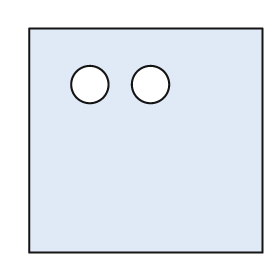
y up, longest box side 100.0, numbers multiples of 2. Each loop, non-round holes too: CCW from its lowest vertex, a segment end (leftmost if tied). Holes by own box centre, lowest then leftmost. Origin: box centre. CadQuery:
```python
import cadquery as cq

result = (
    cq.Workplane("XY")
    .moveTo(-50.0, -48.0)
    .lineTo(50.0, -48.0)
    .lineTo(50.0, 48.0)
    .lineTo(-50.0, 48.0)
    .close()
    .moveTo(-24.0, 24.0)
    .circle(8.0)
    .moveTo(2.0, 24.0)
    .circle(8.0)
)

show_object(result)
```